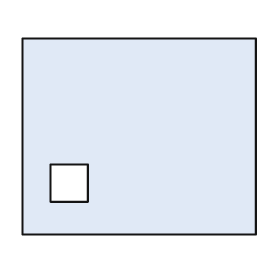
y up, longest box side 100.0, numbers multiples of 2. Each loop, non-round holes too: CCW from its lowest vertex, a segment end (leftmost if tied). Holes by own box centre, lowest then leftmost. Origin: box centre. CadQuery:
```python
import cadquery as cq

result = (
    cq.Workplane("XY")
    .moveTo(-50.0, -42.0)
    .lineTo(50.0, -42.0)
    .lineTo(50.0, 42.0)
    .lineTo(-50.0, 42.0)
    .close()
    .moveTo(-38.0, -28.0)
    .lineTo(-22.0, -28.0)
    .lineTo(-22.0, -12.0)
    .lineTo(-38.0, -12.0)
    .close()
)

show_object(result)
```